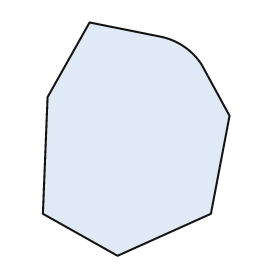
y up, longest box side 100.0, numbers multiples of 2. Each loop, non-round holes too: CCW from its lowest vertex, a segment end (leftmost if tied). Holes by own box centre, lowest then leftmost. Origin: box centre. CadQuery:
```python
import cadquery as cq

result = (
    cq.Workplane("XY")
    .moveTo(-8.0, -50.0)
    .lineTo(32.0, -32.0)
    .lineTo(40.0, 10.0)
    .lineTo(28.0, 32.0)
    .threePointArc((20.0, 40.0), (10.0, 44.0))
    .lineTo(-20.0, 50.0)
    .lineTo(-38.0, 18.0)
    .lineTo(-40.0, -32.0)
    .close()
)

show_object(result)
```